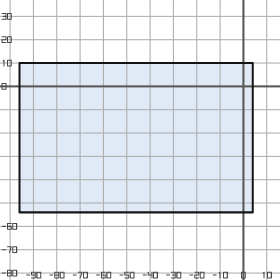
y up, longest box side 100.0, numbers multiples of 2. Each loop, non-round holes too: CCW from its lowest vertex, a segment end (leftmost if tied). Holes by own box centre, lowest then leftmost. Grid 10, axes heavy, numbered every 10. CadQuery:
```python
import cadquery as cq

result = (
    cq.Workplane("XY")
    .moveTo(-96.0, -54.0)
    .lineTo(4.0, -54.0)
    .lineTo(4.0, 10.0)
    .lineTo(-96.0, 10.0)
    .close()
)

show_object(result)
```